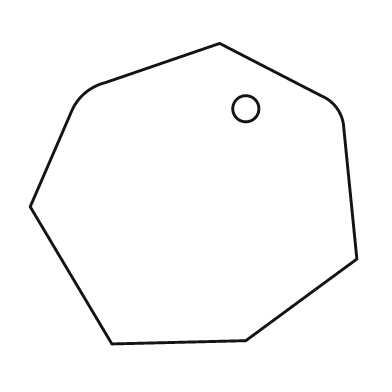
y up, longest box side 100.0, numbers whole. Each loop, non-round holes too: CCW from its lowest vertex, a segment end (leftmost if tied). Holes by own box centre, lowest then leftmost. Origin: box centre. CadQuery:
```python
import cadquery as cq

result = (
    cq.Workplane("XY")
    .moveTo(-25.0, -46.0)
    .lineTo(16.0, -45.0)
    .lineTo(50.0, -20.0)
    .lineTo(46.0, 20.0)
    .threePointArc((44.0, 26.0), (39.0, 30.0))
    .lineTo(8.0, 46.0)
    .lineTo(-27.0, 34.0)
    .threePointArc((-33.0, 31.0), (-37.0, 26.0))
    .lineTo(-50.0, -4.0)
    .close()
    .moveTo(16.0, 26.0)
    .circle(4.0)
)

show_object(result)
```